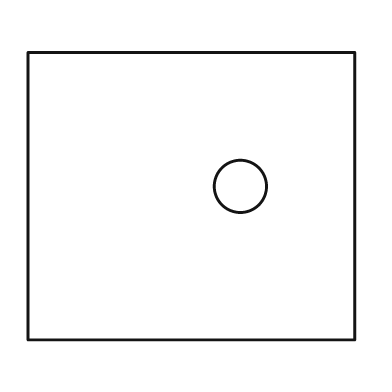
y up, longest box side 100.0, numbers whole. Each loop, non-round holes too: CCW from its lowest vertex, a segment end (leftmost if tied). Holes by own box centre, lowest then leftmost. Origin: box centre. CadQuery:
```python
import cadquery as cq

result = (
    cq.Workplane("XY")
    .moveTo(-50.0, -44.0)
    .lineTo(50.0, -44.0)
    .lineTo(50.0, 44.0)
    .lineTo(-50.0, 44.0)
    .close()
    .moveTo(15.0, 3.0)
    .circle(8.0)
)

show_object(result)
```